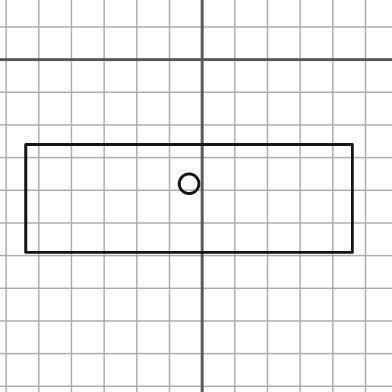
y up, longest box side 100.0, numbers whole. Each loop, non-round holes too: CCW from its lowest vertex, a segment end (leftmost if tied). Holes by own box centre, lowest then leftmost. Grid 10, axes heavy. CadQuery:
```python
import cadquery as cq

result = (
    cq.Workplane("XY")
    .moveTo(-54.0, -59.0)
    .lineTo(46.0, -59.0)
    .lineTo(46.0, -26.0)
    .lineTo(-54.0, -26.0)
    .close()
    .moveTo(-4.0, -38.0)
    .circle(3.0)
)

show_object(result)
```